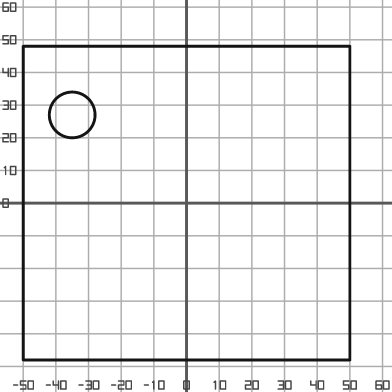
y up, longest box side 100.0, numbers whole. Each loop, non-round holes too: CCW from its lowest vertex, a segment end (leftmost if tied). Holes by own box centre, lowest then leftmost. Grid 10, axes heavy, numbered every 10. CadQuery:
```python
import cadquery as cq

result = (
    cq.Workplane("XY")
    .moveTo(-50.0, -48.0)
    .lineTo(50.0, -48.0)
    .lineTo(50.0, 48.0)
    .lineTo(-50.0, 48.0)
    .close()
    .moveTo(-35.0, 27.0)
    .circle(7.0)
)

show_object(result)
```